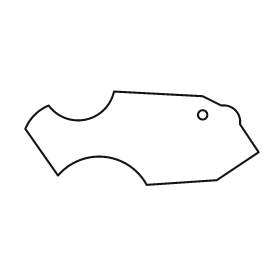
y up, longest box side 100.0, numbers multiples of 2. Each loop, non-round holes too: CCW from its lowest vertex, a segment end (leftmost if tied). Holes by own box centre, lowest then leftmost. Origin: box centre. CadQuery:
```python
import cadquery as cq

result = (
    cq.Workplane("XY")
    .moveTo(2.0, -20.0)
    .lineTo(32.0, -18.0)
    .lineTo(50.0, -6.0)
    .lineTo(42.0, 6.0)
    .threePointArc((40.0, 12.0), (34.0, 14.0))
    .lineTo(26.0, 18.0)
    .lineTo(-12.0, 20.0)
    .threePointArc((-24.0, 8.0), (-40.0, 14.0))
    .threePointArc((-46.0, 10.0), (-50.0, 4.0))
    .lineTo(-36.0, -16.0)
    .threePointArc((-16.0, -8.0), (2.0, -20.0))
    .close()
    .moveTo(26.0, 10.0)
    .circle(2.0)
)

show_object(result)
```